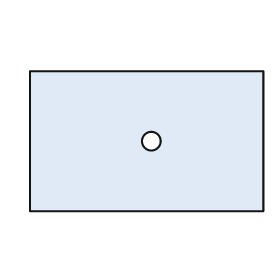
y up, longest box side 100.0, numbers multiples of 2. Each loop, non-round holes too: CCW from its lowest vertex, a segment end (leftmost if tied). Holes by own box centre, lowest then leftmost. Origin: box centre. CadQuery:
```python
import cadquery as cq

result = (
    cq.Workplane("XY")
    .moveTo(-50.0, -30.0)
    .lineTo(50.0, -30.0)
    .lineTo(50.0, 30.0)
    .lineTo(-50.0, 30.0)
    .close()
    .moveTo(2.0, 0.0)
    .circle(4.0)
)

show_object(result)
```